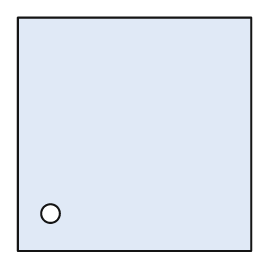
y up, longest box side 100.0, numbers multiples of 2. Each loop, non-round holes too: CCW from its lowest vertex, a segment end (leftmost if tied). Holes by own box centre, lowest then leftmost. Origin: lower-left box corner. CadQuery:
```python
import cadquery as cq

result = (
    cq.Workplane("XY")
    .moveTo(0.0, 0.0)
    .lineTo(100.0, 0.0)
    .lineTo(100.0, 100.0)
    .lineTo(0.0, 100.0)
    .close()
    .moveTo(14.0, 16.0)
    .circle(4.0)
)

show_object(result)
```